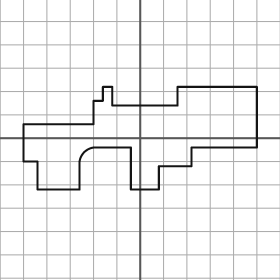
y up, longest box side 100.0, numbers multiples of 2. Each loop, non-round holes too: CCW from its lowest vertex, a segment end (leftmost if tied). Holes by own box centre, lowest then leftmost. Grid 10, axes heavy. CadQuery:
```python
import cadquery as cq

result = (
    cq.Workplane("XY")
    .moveTo(-44.0, -22.0)
    .lineTo(-26.0, -22.0)
    .lineTo(-26.0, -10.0)
    .threePointArc((-24.0, -6.0), (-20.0, -4.0))
    .lineTo(-4.0, -4.0)
    .lineTo(-4.0, -22.0)
    .lineTo(8.0, -22.0)
    .lineTo(8.0, -12.0)
    .lineTo(22.0, -12.0)
    .lineTo(22.0, -4.0)
    .lineTo(50.0, -4.0)
    .lineTo(50.0, 22.0)
    .lineTo(16.0, 22.0)
    .lineTo(16.0, 14.0)
    .lineTo(-12.0, 14.0)
    .lineTo(-12.0, 22.0)
    .lineTo(-16.0, 22.0)
    .lineTo(-16.0, 16.0)
    .lineTo(-20.0, 16.0)
    .lineTo(-20.0, 6.0)
    .lineTo(-50.0, 6.0)
    .lineTo(-50.0, -10.0)
    .lineTo(-44.0, -10.0)
    .close()
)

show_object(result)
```